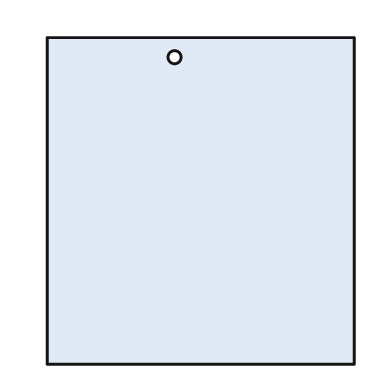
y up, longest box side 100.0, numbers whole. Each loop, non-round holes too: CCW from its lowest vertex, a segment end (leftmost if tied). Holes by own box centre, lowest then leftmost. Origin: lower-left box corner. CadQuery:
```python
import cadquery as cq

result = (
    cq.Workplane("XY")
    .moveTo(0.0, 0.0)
    .lineTo(94.0, 0.0)
    .lineTo(94.0, 100.0)
    .lineTo(0.0, 100.0)
    .close()
    .moveTo(39.0, 94.0)
    .circle(2.0)
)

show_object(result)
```